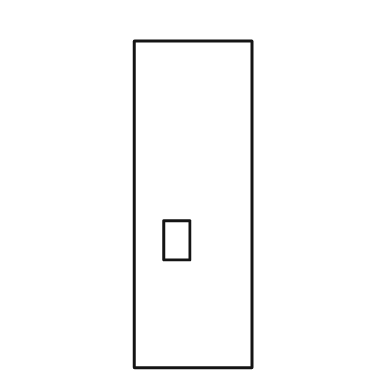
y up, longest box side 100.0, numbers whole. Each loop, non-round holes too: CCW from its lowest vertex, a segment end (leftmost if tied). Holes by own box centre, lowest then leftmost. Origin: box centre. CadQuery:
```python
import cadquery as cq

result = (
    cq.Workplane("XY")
    .moveTo(-18.0, -50.0)
    .lineTo(18.0, -50.0)
    .lineTo(18.0, 50.0)
    .lineTo(-18.0, 50.0)
    .close()
    .moveTo(-9.0, -17.0)
    .lineTo(-1.0, -17.0)
    .lineTo(-1.0, -5.0)
    .lineTo(-9.0, -5.0)
    .close()
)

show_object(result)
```